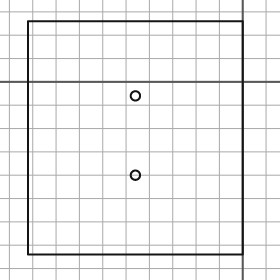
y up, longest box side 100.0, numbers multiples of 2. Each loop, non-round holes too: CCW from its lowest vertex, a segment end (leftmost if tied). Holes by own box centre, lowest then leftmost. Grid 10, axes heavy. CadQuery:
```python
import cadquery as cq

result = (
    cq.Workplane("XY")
    .moveTo(-92.0, -74.0)
    .lineTo(0.0, -74.0)
    .lineTo(0.0, 26.0)
    .lineTo(-92.0, 26.0)
    .close()
    .moveTo(-46.0, -40.0)
    .circle(2.0)
    .moveTo(-46.0, -6.0)
    .circle(2.0)
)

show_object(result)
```